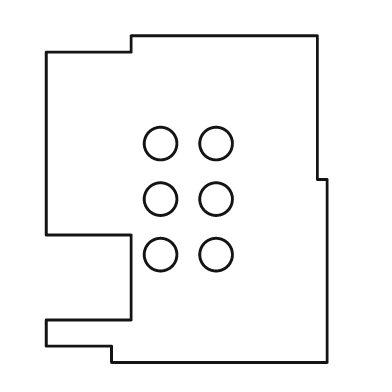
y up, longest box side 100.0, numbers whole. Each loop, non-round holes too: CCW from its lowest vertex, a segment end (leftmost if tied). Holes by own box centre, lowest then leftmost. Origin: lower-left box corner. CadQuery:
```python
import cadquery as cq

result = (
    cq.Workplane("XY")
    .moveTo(20.0, 0.0)
    .lineTo(86.0, 0.0)
    .lineTo(86.0, 56.0)
    .lineTo(83.0, 56.0)
    .lineTo(83.0, 100.0)
    .lineTo(26.0, 100.0)
    .lineTo(26.0, 95.0)
    .lineTo(0.0, 95.0)
    .lineTo(0.0, 39.0)
    .lineTo(26.0, 39.0)
    .lineTo(26.0, 13.0)
    .lineTo(0.0, 13.0)
    .lineTo(0.0, 5.0)
    .lineTo(20.0, 5.0)
    .close()
    .moveTo(35.0, 33.0)
    .circle(5.0)
    .moveTo(52.0, 33.0)
    .circle(5.0)
    .moveTo(35.0, 50.0)
    .circle(5.0)
    .moveTo(52.0, 50.0)
    .circle(5.0)
    .moveTo(35.0, 67.0)
    .circle(5.0)
    .moveTo(52.0, 67.0)
    .circle(5.0)
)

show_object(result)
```